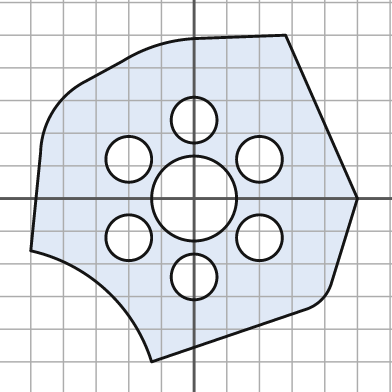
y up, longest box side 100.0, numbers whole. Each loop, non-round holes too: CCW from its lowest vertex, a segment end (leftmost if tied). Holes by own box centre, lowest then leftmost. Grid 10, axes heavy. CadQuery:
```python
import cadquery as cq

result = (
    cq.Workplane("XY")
    .moveTo(-13.0, -50.0)
    .lineTo(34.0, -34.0)
    .threePointArc((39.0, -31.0), (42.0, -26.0))
    .lineTo(50.0, 0.0)
    .lineTo(28.0, 50.0)
    .lineTo(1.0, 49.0)
    .threePointArc((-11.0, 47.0), (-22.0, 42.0))
    .lineTo(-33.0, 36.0)
    .threePointArc((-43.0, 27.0), (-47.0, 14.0))
    .lineTo(-50.0, -16.0)
    .threePointArc((-27.0, -28.0), (-13.0, -50.0))
    .close()
    .moveTo(0.0, -24.0)
    .circle(7.0)
    .moveTo(-20.0, -12.0)
    .circle(7.0)
    .moveTo(20.0, -12.0)
    .circle(7.0)
    .moveTo(0.0, 0.0)
    .circle(13.0)
    .moveTo(-20.0, 12.0)
    .circle(7.0)
    .moveTo(20.0, 12.0)
    .circle(7.0)
    .moveTo(0.0, 24.0)
    .circle(7.0)
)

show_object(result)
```